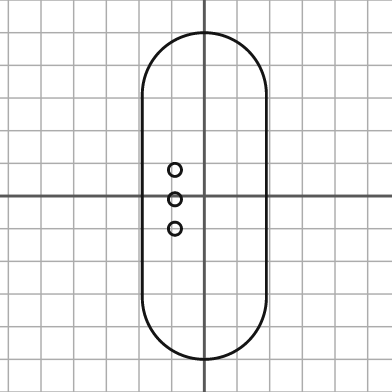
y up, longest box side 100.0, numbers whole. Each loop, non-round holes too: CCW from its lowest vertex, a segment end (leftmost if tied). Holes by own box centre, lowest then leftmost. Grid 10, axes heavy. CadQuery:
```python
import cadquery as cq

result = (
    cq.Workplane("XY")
    .moveTo(-19.0, -31.0)
    .threePointArc((0.0, -50.0), (19.0, -31.0))
    .lineTo(19.0, 31.0)
    .threePointArc((0.0, 50.0), (-19.0, 31.0))
    .close()
    .moveTo(-9.0, -10.0)
    .circle(2.0)
    .moveTo(-9.0, -1.0)
    .circle(2.0)
    .moveTo(-9.0, 8.0)
    .circle(2.0)
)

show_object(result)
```